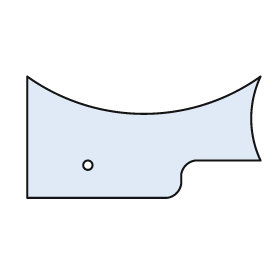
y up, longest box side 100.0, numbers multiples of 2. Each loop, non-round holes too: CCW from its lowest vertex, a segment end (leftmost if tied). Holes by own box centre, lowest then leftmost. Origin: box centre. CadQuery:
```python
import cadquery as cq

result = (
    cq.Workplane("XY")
    .moveTo(-50.0, -26.0)
    .lineTo(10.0, -26.0)
    .threePointArc((14.0, -24.0), (16.0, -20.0))
    .lineTo(16.0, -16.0)
    .threePointArc((18.0, -12.0), (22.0, -10.0))
    .lineTo(50.0, -10.0)
    .threePointArc((46.0, 8.0), (50.0, 26.0))
    .threePointArc((0.0, 10.0), (-50.0, 26.0))
    .close()
    .moveTo(-24.0, -12.0)
    .circle(2.0)
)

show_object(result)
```